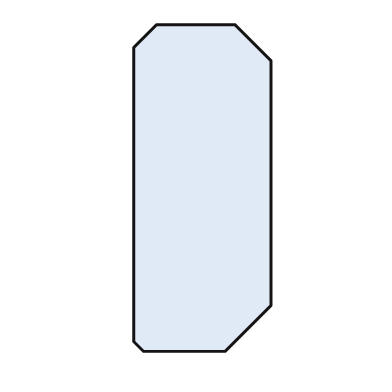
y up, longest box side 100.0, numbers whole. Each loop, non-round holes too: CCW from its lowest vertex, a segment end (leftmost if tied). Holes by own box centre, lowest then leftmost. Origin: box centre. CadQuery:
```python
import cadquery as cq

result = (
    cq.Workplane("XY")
    .moveTo(-18.0, -50.0)
    .lineTo(7.0, -50.0)
    .lineTo(21.0, -36.0)
    .lineTo(21.0, 39.0)
    .lineTo(10.0, 50.0)
    .lineTo(-14.0, 50.0)
    .lineTo(-21.0, 43.0)
    .lineTo(-21.0, -47.0)
    .close()
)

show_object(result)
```